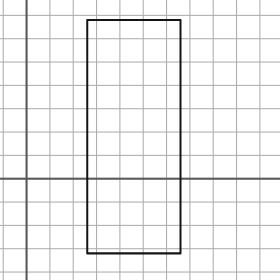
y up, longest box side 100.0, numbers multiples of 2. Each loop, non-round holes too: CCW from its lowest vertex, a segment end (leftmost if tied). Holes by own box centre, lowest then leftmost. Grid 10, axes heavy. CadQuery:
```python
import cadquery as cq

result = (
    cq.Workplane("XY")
    .moveTo(26.0, -32.0)
    .lineTo(66.0, -32.0)
    .lineTo(66.0, 68.0)
    .lineTo(26.0, 68.0)
    .close()
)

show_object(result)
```